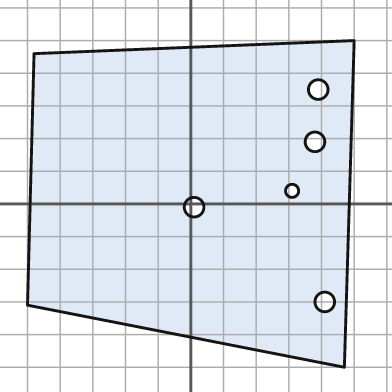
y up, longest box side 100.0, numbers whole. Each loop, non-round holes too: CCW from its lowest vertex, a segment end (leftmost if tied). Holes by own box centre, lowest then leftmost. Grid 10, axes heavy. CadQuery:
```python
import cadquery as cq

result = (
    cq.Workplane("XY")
    .moveTo(47.0, -50.0)
    .lineTo(50.0, 50.0)
    .lineTo(-48.0, 46.0)
    .lineTo(-50.0, -31.0)
    .close()
    .moveTo(41.0, -30.0)
    .circle(3.0)
    .moveTo(1.0, -1.0)
    .circle(3.0)
    .moveTo(31.0, 4.0)
    .circle(2.0)
    .moveTo(38.0, 19.0)
    .circle(3.0)
    .moveTo(39.0, 35.0)
    .circle(3.0)
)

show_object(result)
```